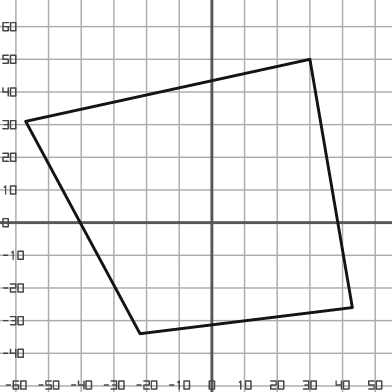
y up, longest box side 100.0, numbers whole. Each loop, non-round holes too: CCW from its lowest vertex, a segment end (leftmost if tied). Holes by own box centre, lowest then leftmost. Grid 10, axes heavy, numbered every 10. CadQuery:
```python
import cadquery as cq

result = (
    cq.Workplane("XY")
    .moveTo(-22.0, -34.0)
    .lineTo(43.0, -26.0)
    .lineTo(30.0, 50.0)
    .lineTo(-57.0, 31.0)
    .close()
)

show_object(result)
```